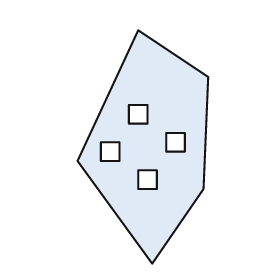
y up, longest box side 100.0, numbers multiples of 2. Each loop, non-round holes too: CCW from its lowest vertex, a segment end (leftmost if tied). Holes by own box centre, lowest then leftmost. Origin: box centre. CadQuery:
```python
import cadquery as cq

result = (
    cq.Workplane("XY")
    .moveTo(4.0, -50.0)
    .lineTo(26.0, -18.0)
    .lineTo(28.0, 30.0)
    .lineTo(-2.0, 50.0)
    .lineTo(-28.0, -6.0)
    .close()
    .moveTo(-2.0, -18.0)
    .lineTo(6.0, -18.0)
    .lineTo(6.0, -10.0)
    .lineTo(-2.0, -10.0)
    .close()
    .moveTo(-18.0, -6.0)
    .lineTo(-10.0, -6.0)
    .lineTo(-10.0, 2.0)
    .lineTo(-18.0, 2.0)
    .close()
    .moveTo(10.0, -2.0)
    .lineTo(18.0, -2.0)
    .lineTo(18.0, 6.0)
    .lineTo(10.0, 6.0)
    .close()
    .moveTo(-6.0, 10.0)
    .lineTo(2.0, 10.0)
    .lineTo(2.0, 18.0)
    .lineTo(-6.0, 18.0)
    .close()
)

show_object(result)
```